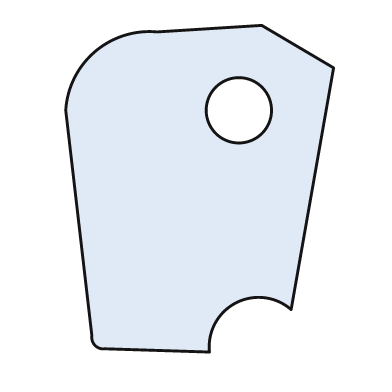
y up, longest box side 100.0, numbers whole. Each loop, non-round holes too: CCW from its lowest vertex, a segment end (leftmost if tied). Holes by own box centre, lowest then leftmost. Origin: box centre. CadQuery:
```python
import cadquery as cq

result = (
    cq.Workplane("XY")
    .moveTo(3.0, -50.0)
    .threePointArc((11.0, -35.0), (28.0, -37.0))
    .lineTo(41.0, 37.0)
    .lineTo(19.0, 50.0)
    .lineTo(-13.0, 48.0)
    .threePointArc((-32.0, 42.0), (-41.0, 24.0))
    .lineTo(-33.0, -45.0)
    .threePointArc((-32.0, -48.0), (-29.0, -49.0))
    .close()
    .moveTo(12.0, 24.0)
    .circle(10.0)
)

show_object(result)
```